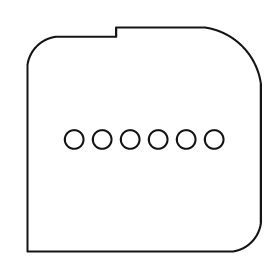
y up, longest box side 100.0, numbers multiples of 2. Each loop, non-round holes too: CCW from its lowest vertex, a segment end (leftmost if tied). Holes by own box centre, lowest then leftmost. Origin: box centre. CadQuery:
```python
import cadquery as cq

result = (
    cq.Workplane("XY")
    .moveTo(-50.0, -48.0)
    .lineTo(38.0, -48.0)
    .threePointArc((46.0, -44.0), (50.0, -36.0))
    .lineTo(50.0, 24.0)
    .threePointArc((42.0, 40.0), (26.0, 48.0))
    .lineTo(-12.0, 48.0)
    .lineTo(-12.0, 44.0)
    .lineTo(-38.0, 44.0)
    .threePointArc((-46.0, 40.0), (-50.0, 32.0))
    .close()
    .moveTo(-30.0, 0.0)
    .circle(4.0)
    .moveTo(-18.0, 0.0)
    .circle(4.0)
    .moveTo(-6.0, 0.0)
    .circle(4.0)
    .moveTo(6.0, 0.0)
    .circle(4.0)
    .moveTo(18.0, 0.0)
    .circle(4.0)
    .moveTo(30.0, 0.0)
    .circle(4.0)
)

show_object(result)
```